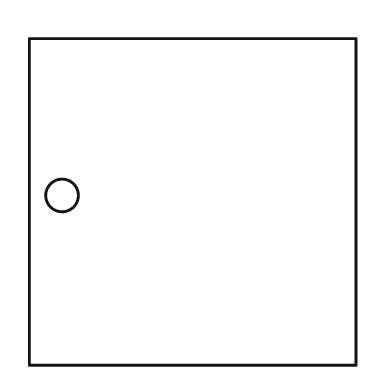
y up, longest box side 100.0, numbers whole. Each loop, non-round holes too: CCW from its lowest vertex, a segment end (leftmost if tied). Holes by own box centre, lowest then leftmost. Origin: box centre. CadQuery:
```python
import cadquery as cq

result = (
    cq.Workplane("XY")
    .moveTo(-50.0, -50.0)
    .lineTo(50.0, -50.0)
    .lineTo(50.0, 50.0)
    .lineTo(-50.0, 50.0)
    .close()
    .moveTo(-40.0, 2.0)
    .circle(5.0)
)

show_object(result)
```